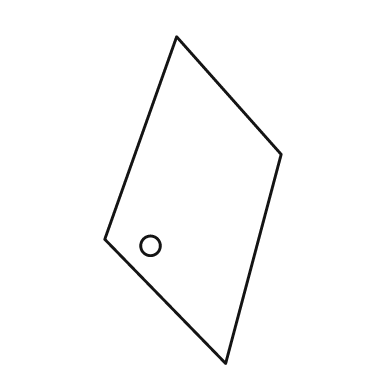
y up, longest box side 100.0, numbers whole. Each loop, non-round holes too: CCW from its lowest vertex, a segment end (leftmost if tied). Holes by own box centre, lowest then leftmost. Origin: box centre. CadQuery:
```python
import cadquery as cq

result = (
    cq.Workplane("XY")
    .moveTo(10.0, -50.0)
    .lineTo(27.0, 14.0)
    .lineTo(-5.0, 50.0)
    .lineTo(-27.0, -12.0)
    .close()
    .moveTo(-13.0, -14.0)
    .circle(3.0)
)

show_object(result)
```